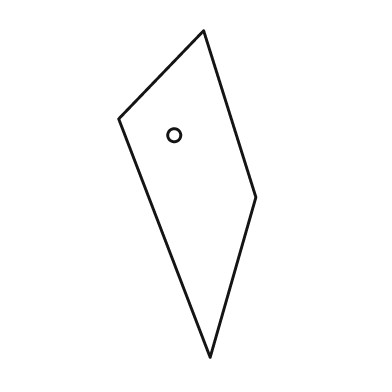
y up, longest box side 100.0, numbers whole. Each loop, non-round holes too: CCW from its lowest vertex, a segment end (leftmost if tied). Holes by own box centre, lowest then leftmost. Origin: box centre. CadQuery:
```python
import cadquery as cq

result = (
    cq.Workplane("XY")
    .moveTo(7.0, -50.0)
    .lineTo(21.0, -1.0)
    .lineTo(5.0, 50.0)
    .lineTo(-21.0, 23.0)
    .close()
    .moveTo(-4.0, 18.0)
    .circle(2.0)
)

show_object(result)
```